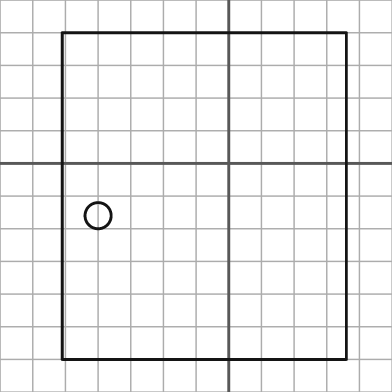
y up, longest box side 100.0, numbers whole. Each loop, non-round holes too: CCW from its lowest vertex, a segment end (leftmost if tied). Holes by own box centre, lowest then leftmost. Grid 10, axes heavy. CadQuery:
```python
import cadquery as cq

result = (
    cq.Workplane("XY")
    .moveTo(-51.0, -60.0)
    .lineTo(36.0, -60.0)
    .lineTo(36.0, 40.0)
    .lineTo(-51.0, 40.0)
    .close()
    .moveTo(-40.0, -16.0)
    .circle(4.0)
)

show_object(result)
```